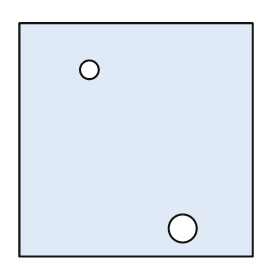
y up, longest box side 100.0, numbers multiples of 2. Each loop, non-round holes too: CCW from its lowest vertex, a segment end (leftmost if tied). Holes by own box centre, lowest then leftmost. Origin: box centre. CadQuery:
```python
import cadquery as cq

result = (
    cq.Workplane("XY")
    .moveTo(-50.0, -50.0)
    .lineTo(50.0, -50.0)
    .lineTo(50.0, 50.0)
    .lineTo(-50.0, 50.0)
    .close()
    .moveTo(20.0, -38.0)
    .circle(6.0)
    .moveTo(-20.0, 30.0)
    .circle(4.0)
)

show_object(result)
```